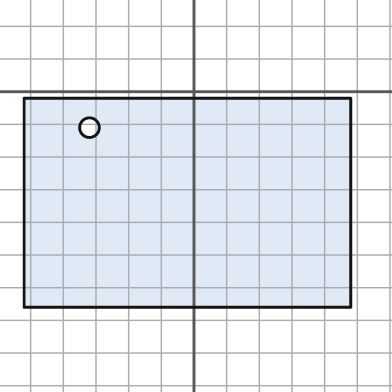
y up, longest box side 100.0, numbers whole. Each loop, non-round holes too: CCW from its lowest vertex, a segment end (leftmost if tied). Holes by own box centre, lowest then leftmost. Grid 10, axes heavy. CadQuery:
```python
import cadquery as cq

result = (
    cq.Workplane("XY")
    .moveTo(-52.0, -66.0)
    .lineTo(48.0, -66.0)
    .lineTo(48.0, -2.0)
    .lineTo(-52.0, -2.0)
    .close()
    .moveTo(-32.0, -11.0)
    .circle(3.0)
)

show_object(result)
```